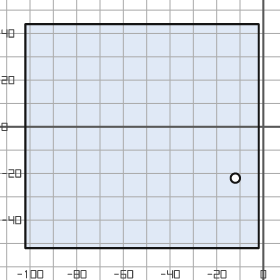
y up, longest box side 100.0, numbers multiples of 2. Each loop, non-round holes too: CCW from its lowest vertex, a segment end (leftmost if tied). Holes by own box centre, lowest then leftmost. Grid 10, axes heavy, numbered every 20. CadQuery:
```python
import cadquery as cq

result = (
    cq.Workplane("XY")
    .moveTo(-102.0, -52.0)
    .lineTo(-2.0, -52.0)
    .lineTo(-2.0, 44.0)
    .lineTo(-102.0, 44.0)
    .close()
    .moveTo(-12.0, -22.0)
    .circle(2.0)
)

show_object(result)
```